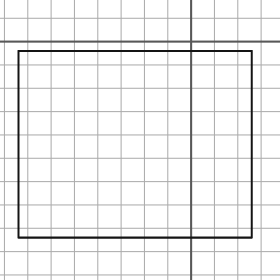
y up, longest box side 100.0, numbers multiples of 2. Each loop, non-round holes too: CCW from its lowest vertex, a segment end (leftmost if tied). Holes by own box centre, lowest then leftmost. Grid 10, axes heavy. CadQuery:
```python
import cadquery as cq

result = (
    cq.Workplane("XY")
    .moveTo(-74.0, -84.0)
    .lineTo(26.0, -84.0)
    .lineTo(26.0, -4.0)
    .lineTo(-74.0, -4.0)
    .close()
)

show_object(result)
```